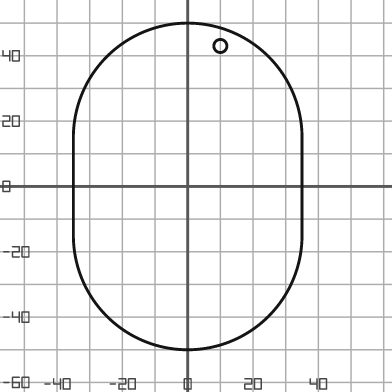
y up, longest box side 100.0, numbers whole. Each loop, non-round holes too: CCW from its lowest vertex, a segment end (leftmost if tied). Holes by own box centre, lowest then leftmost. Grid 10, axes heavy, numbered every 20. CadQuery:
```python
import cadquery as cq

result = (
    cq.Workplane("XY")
    .moveTo(-35.0, -15.0)
    .threePointArc((0.0, -50.0), (35.0, -15.0))
    .lineTo(35.0, 15.0)
    .threePointArc((0.0, 50.0), (-35.0, 15.0))
    .close()
    .moveTo(10.0, 43.0)
    .circle(2.0)
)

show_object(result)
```